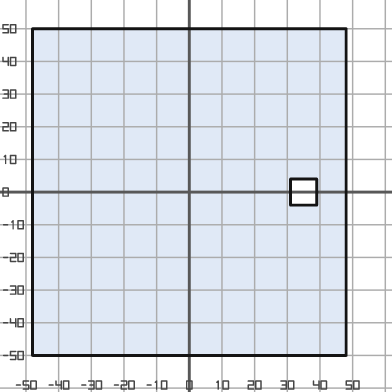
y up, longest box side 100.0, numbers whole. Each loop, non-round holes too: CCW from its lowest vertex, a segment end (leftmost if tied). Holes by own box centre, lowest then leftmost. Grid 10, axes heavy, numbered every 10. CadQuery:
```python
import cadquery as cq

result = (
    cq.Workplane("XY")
    .moveTo(-48.0, -50.0)
    .lineTo(48.0, -50.0)
    .lineTo(48.0, 50.0)
    .lineTo(-48.0, 50.0)
    .close()
    .moveTo(31.0, -4.0)
    .lineTo(39.0, -4.0)
    .lineTo(39.0, 4.0)
    .lineTo(31.0, 4.0)
    .close()
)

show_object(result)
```